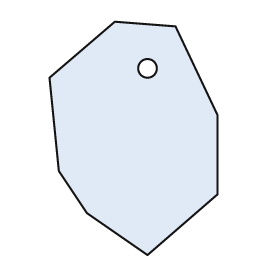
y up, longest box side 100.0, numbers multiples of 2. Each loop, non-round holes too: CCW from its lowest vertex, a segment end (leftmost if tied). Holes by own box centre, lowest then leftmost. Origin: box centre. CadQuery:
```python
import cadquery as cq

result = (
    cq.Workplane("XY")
    .moveTo(6.0, -50.0)
    .lineTo(36.0, -24.0)
    .lineTo(36.0, 10.0)
    .lineTo(18.0, 48.0)
    .lineTo(-8.0, 50.0)
    .lineTo(-36.0, 26.0)
    .lineTo(-32.0, -14.0)
    .lineTo(-20.0, -32.0)
    .close()
    .moveTo(6.0, 30.0)
    .circle(4.0)
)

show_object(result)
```